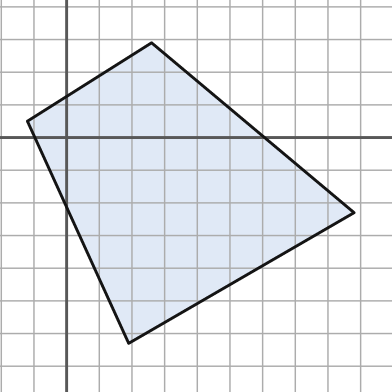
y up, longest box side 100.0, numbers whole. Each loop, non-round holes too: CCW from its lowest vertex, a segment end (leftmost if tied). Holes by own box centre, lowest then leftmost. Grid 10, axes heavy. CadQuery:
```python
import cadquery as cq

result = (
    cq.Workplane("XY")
    .moveTo(19.0, -63.0)
    .lineTo(88.0, -23.0)
    .lineTo(26.0, 29.0)
    .lineTo(-12.0, 5.0)
    .close()
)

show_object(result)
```